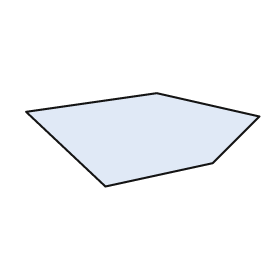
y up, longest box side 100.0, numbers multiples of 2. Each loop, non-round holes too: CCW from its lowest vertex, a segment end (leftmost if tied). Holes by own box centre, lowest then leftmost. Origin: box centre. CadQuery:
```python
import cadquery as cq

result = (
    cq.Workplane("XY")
    .moveTo(-16.0, -20.0)
    .lineTo(30.0, -10.0)
    .lineTo(50.0, 10.0)
    .lineTo(6.0, 20.0)
    .lineTo(-50.0, 12.0)
    .close()
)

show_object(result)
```